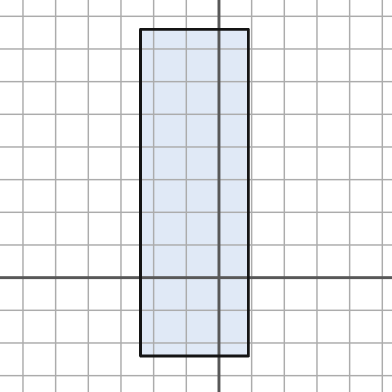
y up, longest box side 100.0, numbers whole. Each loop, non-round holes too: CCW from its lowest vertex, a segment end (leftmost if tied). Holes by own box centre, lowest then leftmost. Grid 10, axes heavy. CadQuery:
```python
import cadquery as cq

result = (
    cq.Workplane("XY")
    .moveTo(-24.0, -24.0)
    .lineTo(9.0, -24.0)
    .lineTo(9.0, 76.0)
    .lineTo(-24.0, 76.0)
    .close()
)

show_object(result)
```